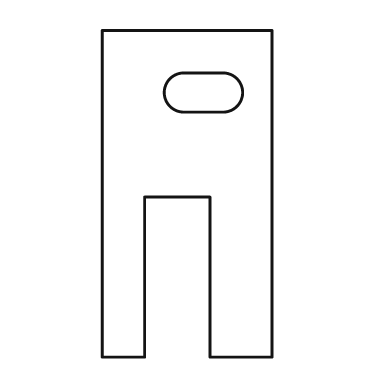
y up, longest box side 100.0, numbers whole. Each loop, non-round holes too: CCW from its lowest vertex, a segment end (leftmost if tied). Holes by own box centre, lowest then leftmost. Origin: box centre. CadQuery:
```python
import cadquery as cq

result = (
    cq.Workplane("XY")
    .moveTo(-26.0, -50.0)
    .lineTo(-13.0, -50.0)
    .lineTo(-13.0, -1.0)
    .lineTo(7.0, -1.0)
    .lineTo(7.0, -50.0)
    .lineTo(26.0, -50.0)
    .lineTo(26.0, 50.0)
    .lineTo(-26.0, 50.0)
    .close()
    .moveTo(-1.0, 25.0)
    .lineTo(11.0, 25.0)
    .threePointArc((17.0, 31.0), (11.0, 37.0))
    .lineTo(-1.0, 37.0)
    .threePointArc((-7.0, 31.0), (-1.0, 25.0))
    .close()
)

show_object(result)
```